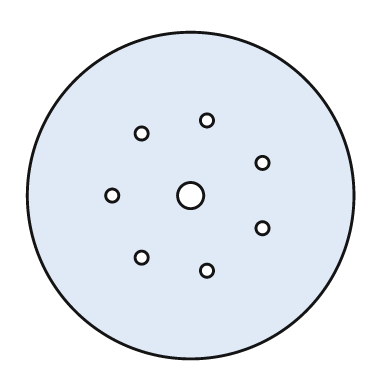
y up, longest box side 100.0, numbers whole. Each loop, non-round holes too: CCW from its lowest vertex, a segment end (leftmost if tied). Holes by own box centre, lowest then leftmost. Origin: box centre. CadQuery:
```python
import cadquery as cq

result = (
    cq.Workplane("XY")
    .moveTo(0.0, 0.0)
    .circle(50.0)
    .moveTo(5.0, -23.0)
    .circle(2.0)
    .moveTo(-15.0, -19.0)
    .circle(2.0)
    .moveTo(22.0, -10.0)
    .circle(2.0)
    .moveTo(-24.0, 0.0)
    .circle(2.0)
    .moveTo(0.0, 0.0)
    .circle(4.0)
    .moveTo(22.0, 10.0)
    .circle(2.0)
    .moveTo(-15.0, 19.0)
    .circle(2.0)
    .moveTo(5.0, 23.0)
    .circle(2.0)
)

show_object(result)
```